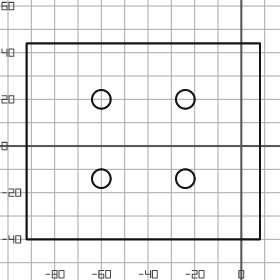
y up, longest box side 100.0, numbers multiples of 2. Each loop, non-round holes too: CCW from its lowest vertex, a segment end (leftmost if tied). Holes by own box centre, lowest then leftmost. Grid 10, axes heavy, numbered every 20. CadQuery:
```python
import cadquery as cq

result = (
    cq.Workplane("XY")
    .moveTo(-92.0, -40.0)
    .lineTo(8.0, -40.0)
    .lineTo(8.0, 44.0)
    .lineTo(-92.0, 44.0)
    .close()
    .moveTo(-60.0, -14.0)
    .circle(4.0)
    .moveTo(-24.0, -14.0)
    .circle(4.0)
    .moveTo(-60.0, 20.0)
    .circle(4.0)
    .moveTo(-24.0, 20.0)
    .circle(4.0)
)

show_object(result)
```